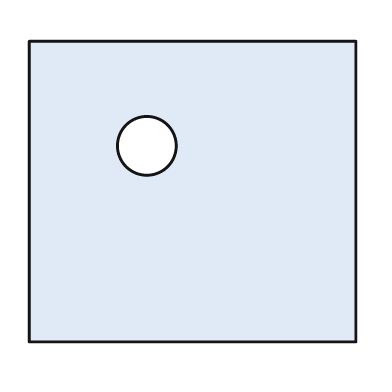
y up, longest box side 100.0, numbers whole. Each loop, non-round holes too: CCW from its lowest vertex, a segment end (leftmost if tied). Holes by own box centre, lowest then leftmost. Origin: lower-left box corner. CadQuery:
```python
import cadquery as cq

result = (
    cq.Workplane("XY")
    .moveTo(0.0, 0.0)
    .lineTo(100.0, 0.0)
    .lineTo(100.0, 92.0)
    .lineTo(0.0, 92.0)
    .close()
    .moveTo(36.0, 60.0)
    .circle(9.0)
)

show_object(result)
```